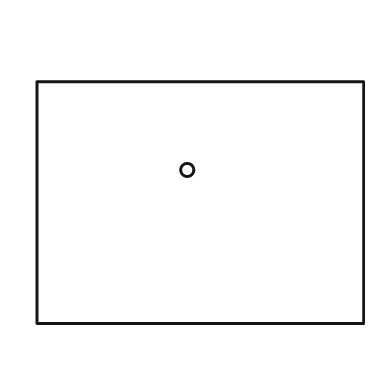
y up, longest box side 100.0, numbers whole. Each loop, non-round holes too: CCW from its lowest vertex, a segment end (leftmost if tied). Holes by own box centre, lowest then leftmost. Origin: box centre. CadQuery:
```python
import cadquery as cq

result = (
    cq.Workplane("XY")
    .moveTo(-50.0, -37.0)
    .lineTo(50.0, -37.0)
    .lineTo(50.0, 37.0)
    .lineTo(-50.0, 37.0)
    .close()
    .moveTo(-4.0, 10.0)
    .circle(2.0)
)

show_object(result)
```